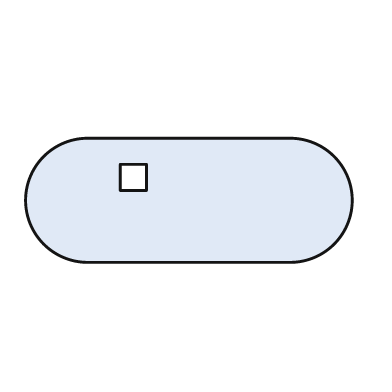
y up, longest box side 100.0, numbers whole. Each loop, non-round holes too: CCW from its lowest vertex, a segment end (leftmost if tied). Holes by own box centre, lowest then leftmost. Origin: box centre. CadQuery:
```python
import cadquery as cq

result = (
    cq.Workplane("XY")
    .moveTo(-31.0, -19.0)
    .lineTo(31.0, -19.0)
    .threePointArc((50.0, 0.0), (31.0, 19.0))
    .lineTo(-31.0, 19.0)
    .threePointArc((-50.0, 0.0), (-31.0, -19.0))
    .close()
    .moveTo(-21.0, 3.0)
    .lineTo(-13.0, 3.0)
    .lineTo(-13.0, 11.0)
    .lineTo(-21.0, 11.0)
    .close()
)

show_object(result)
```